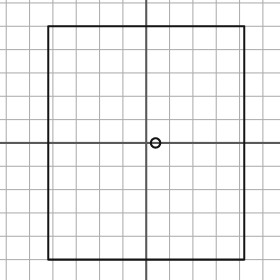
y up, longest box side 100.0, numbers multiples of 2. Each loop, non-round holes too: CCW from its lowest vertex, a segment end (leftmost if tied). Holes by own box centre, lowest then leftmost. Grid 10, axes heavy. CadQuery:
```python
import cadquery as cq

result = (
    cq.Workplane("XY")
    .moveTo(-42.0, -50.0)
    .lineTo(42.0, -50.0)
    .lineTo(42.0, 50.0)
    .lineTo(-42.0, 50.0)
    .close()
    .moveTo(4.0, 0.0)
    .circle(2.0)
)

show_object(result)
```